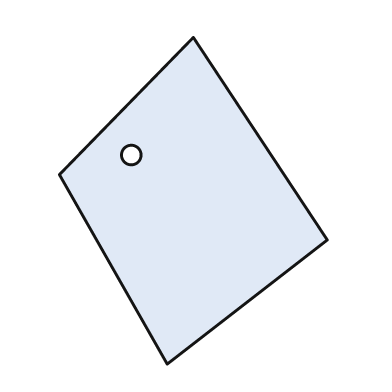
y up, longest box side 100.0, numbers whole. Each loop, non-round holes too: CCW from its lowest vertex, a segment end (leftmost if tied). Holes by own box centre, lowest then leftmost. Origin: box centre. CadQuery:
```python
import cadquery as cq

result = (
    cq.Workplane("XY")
    .moveTo(-8.0, -50.0)
    .lineTo(41.0, -12.0)
    .lineTo(0.0, 50.0)
    .lineTo(-41.0, 8.0)
    .close()
    .moveTo(-19.0, 14.0)
    .circle(3.0)
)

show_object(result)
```